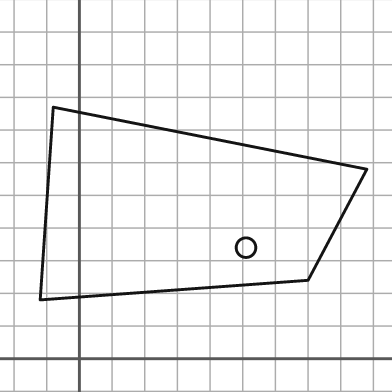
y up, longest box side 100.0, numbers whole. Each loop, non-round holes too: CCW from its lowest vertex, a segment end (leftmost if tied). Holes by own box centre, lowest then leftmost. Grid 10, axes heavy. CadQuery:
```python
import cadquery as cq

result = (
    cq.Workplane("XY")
    .moveTo(-12.0, 18.0)
    .lineTo(70.0, 24.0)
    .lineTo(88.0, 58.0)
    .lineTo(-8.0, 77.0)
    .close()
    .moveTo(51.0, 34.0)
    .circle(3.0)
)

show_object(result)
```